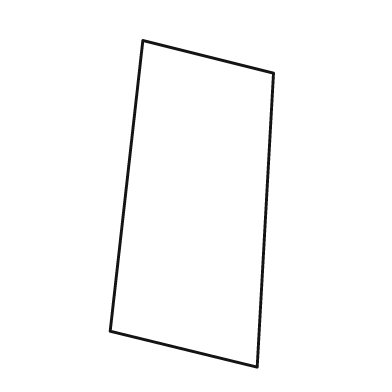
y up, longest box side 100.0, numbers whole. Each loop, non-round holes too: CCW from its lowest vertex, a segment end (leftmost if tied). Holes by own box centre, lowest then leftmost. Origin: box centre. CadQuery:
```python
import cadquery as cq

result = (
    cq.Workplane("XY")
    .moveTo(20.0, -50.0)
    .lineTo(25.0, 40.0)
    .lineTo(-15.0, 50.0)
    .lineTo(-25.0, -39.0)
    .close()
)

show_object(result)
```